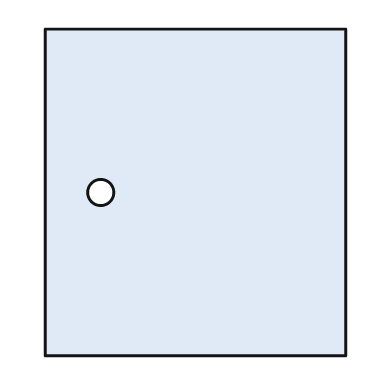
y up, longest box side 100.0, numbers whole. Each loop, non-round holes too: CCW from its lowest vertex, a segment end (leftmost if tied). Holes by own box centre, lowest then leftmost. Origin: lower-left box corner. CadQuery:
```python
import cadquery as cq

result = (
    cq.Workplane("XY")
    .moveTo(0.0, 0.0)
    .lineTo(92.0, 0.0)
    .lineTo(92.0, 100.0)
    .lineTo(0.0, 100.0)
    .close()
    .moveTo(17.0, 50.0)
    .circle(4.0)
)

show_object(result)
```